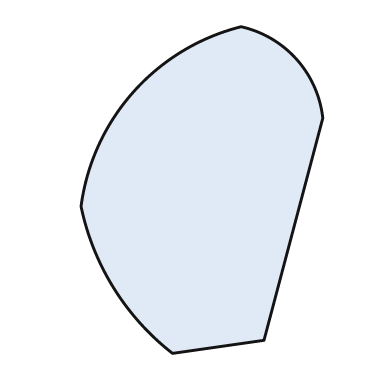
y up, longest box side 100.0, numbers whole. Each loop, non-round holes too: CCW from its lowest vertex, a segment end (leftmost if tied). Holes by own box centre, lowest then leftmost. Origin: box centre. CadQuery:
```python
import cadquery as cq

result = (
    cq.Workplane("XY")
    .moveTo(-9.0, -50.0)
    .lineTo(19.0, -46.0)
    .lineTo(37.0, 22.0)
    .threePointArc((29.0, 40.0), (12.0, 50.0))
    .threePointArc((-21.0, 30.0), (-37.0, -5.0))
    .threePointArc((-27.0, -30.0), (-9.0, -50.0))
    .close()
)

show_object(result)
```